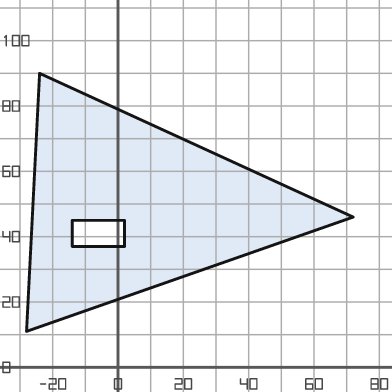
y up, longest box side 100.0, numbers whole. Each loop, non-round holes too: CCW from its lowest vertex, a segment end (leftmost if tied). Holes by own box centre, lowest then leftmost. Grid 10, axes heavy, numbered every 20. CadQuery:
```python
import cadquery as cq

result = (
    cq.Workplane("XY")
    .moveTo(-28.0, 11.0)
    .lineTo(72.0, 46.0)
    .lineTo(-24.0, 90.0)
    .close()
    .moveTo(-14.0, 37.0)
    .lineTo(2.0, 37.0)
    .lineTo(2.0, 45.0)
    .lineTo(-14.0, 45.0)
    .close()
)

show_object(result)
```